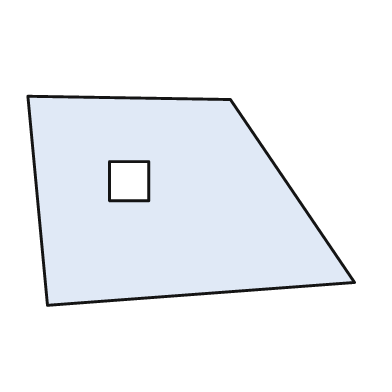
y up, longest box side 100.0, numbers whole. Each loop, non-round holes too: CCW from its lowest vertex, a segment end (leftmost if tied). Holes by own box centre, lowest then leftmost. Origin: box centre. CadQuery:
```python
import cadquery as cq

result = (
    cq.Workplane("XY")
    .moveTo(-44.0, -32.0)
    .lineTo(50.0, -25.0)
    .lineTo(12.0, 31.0)
    .lineTo(-50.0, 32.0)
    .close()
    .moveTo(-25.0, 0.0)
    .lineTo(-13.0, 0.0)
    .lineTo(-13.0, 12.0)
    .lineTo(-25.0, 12.0)
    .close()
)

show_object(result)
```